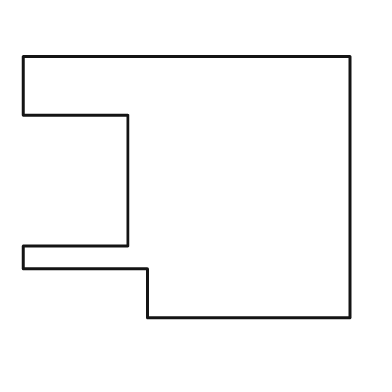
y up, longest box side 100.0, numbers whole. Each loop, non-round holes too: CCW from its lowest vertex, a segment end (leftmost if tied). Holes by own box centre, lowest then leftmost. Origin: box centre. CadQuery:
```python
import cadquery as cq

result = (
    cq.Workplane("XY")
    .moveTo(-12.0, -40.0)
    .lineTo(50.0, -40.0)
    .lineTo(50.0, 40.0)
    .lineTo(-50.0, 40.0)
    .lineTo(-50.0, 22.0)
    .lineTo(-18.0, 22.0)
    .lineTo(-18.0, -18.0)
    .lineTo(-50.0, -18.0)
    .lineTo(-50.0, -25.0)
    .lineTo(-12.0, -25.0)
    .close()
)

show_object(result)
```